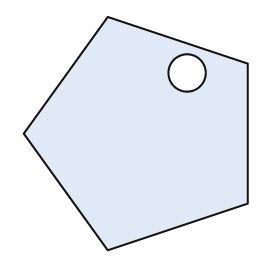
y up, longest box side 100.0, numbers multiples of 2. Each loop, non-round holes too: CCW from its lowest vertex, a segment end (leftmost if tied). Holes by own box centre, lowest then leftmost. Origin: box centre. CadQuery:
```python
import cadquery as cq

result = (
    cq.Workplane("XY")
    .moveTo(-12.0, -50.0)
    .lineTo(48.0, -30.0)
    .lineTo(48.0, 30.0)
    .lineTo(-12.0, 50.0)
    .lineTo(-48.0, 0.0)
    .close()
    .moveTo(22.0, 26.0)
    .circle(8.0)
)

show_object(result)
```